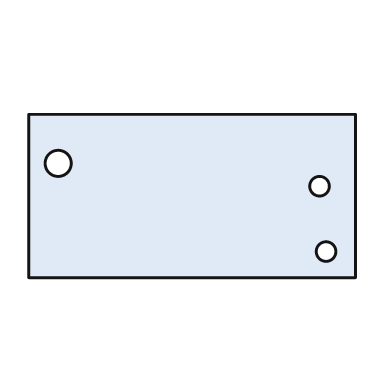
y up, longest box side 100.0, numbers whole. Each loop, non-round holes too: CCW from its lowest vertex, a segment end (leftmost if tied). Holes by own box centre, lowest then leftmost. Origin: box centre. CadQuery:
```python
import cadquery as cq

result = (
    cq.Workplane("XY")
    .moveTo(-50.0, -25.0)
    .lineTo(50.0, -25.0)
    .lineTo(50.0, 25.0)
    .lineTo(-50.0, 25.0)
    .close()
    .moveTo(41.0, -17.0)
    .circle(3.0)
    .moveTo(39.0, 3.0)
    .circle(3.0)
    .moveTo(-41.0, 10.0)
    .circle(4.0)
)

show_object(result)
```